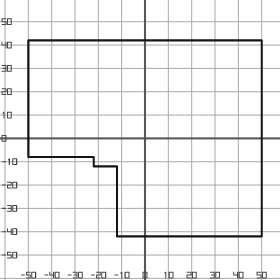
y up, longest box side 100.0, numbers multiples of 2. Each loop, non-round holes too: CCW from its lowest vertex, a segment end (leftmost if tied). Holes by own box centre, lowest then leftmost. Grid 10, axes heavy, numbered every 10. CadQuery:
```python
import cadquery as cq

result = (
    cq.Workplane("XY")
    .moveTo(-12.0, -42.0)
    .lineTo(50.0, -42.0)
    .lineTo(50.0, 42.0)
    .lineTo(-50.0, 42.0)
    .lineTo(-50.0, -8.0)
    .lineTo(-22.0, -8.0)
    .lineTo(-22.0, -12.0)
    .lineTo(-12.0, -12.0)
    .close()
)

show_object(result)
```